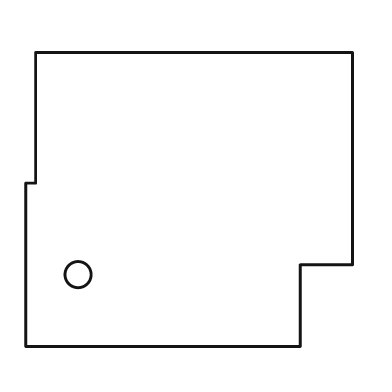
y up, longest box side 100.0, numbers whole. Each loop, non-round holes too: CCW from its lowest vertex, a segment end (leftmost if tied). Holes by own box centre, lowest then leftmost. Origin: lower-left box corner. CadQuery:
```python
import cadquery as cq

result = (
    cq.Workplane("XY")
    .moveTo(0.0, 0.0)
    .lineTo(84.0, 0.0)
    .lineTo(84.0, 25.0)
    .lineTo(100.0, 25.0)
    .lineTo(100.0, 90.0)
    .lineTo(3.0, 90.0)
    .lineTo(3.0, 50.0)
    .lineTo(0.0, 50.0)
    .close()
    .moveTo(16.0, 22.0)
    .circle(4.0)
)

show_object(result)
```